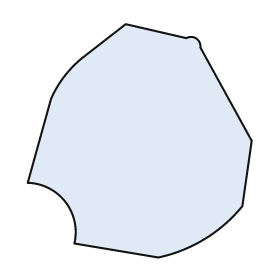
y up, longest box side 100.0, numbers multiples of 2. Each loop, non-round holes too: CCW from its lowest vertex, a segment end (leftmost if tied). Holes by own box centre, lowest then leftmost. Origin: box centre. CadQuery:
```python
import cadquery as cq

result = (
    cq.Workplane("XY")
    .moveTo(8.0, -50.0)
    .threePointArc((28.0, -42.0), (44.0, -28.0))
    .lineTo(48.0, 0.0)
    .lineTo(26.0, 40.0)
    .threePointArc((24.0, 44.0), (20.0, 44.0))
    .lineTo(-6.0, 50.0)
    .lineTo(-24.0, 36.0)
    .threePointArc((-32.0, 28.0), (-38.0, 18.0))
    .lineTo(-48.0, -18.0)
    .threePointArc((-32.0, -26.0), (-28.0, -44.0))
    .close()
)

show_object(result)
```